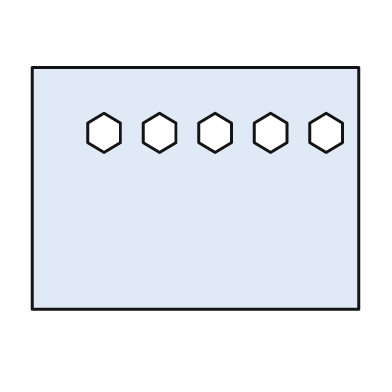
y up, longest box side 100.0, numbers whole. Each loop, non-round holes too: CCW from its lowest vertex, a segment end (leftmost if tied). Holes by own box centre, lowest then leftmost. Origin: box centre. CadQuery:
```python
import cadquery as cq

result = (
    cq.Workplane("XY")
    .moveTo(-50.0, -37.0)
    .lineTo(50.0, -37.0)
    .lineTo(50.0, 37.0)
    .lineTo(-50.0, 37.0)
    .close()
    .moveTo(-28.0, 11.0)
    .lineTo(-23.0, 14.0)
    .lineTo(-23.0, 20.0)
    .lineTo(-28.0, 23.0)
    .lineTo(-33.0, 20.0)
    .lineTo(-33.0, 14.0)
    .close()
    .moveTo(-11.0, 11.0)
    .lineTo(-6.0, 14.0)
    .lineTo(-6.0, 20.0)
    .lineTo(-11.0, 23.0)
    .lineTo(-16.0, 20.0)
    .lineTo(-16.0, 14.0)
    .close()
    .moveTo(6.0, 11.0)
    .lineTo(11.0, 14.0)
    .lineTo(11.0, 20.0)
    .lineTo(6.0, 23.0)
    .lineTo(1.0, 20.0)
    .lineTo(1.0, 14.0)
    .close()
    .moveTo(23.0, 11.0)
    .lineTo(28.0, 14.0)
    .lineTo(28.0, 20.0)
    .lineTo(23.0, 23.0)
    .lineTo(18.0, 20.0)
    .lineTo(18.0, 14.0)
    .close()
    .moveTo(40.0, 11.0)
    .lineTo(45.0, 14.0)
    .lineTo(45.0, 20.0)
    .lineTo(40.0, 23.0)
    .lineTo(35.0, 20.0)
    .lineTo(35.0, 14.0)
    .close()
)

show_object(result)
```